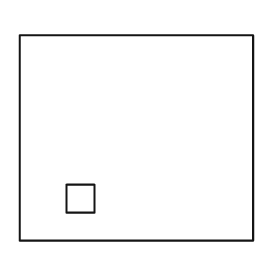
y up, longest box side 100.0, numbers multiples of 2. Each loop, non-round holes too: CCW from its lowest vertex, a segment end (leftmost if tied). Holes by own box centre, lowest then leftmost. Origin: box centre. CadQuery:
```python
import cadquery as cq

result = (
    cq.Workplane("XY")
    .moveTo(-50.0, -44.0)
    .lineTo(50.0, -44.0)
    .lineTo(50.0, 44.0)
    .lineTo(-50.0, 44.0)
    .close()
    .moveTo(-30.0, -32.0)
    .lineTo(-18.0, -32.0)
    .lineTo(-18.0, -20.0)
    .lineTo(-30.0, -20.0)
    .close()
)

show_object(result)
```